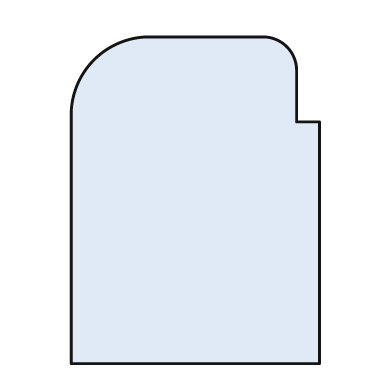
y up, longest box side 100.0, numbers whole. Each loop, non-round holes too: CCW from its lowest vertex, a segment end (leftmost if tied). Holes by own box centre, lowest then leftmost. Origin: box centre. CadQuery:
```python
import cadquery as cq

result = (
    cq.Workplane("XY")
    .moveTo(-38.0, -50.0)
    .lineTo(38.0, -50.0)
    .lineTo(38.0, 24.0)
    .lineTo(31.0, 24.0)
    .lineTo(31.0, 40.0)
    .threePointArc((28.0, 47.0), (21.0, 50.0))
    .lineTo(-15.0, 50.0)
    .threePointArc((-31.0, 43.0), (-38.0, 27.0))
    .close()
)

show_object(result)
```